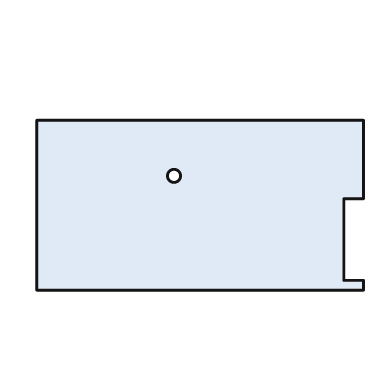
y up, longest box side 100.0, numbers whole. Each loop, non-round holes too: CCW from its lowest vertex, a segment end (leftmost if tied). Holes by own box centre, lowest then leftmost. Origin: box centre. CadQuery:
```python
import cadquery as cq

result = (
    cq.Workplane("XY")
    .moveTo(-50.0, -26.0)
    .lineTo(50.0, -26.0)
    .lineTo(50.0, -23.0)
    .lineTo(44.0, -23.0)
    .lineTo(44.0, 2.0)
    .lineTo(50.0, 2.0)
    .lineTo(50.0, 26.0)
    .lineTo(-50.0, 26.0)
    .close()
    .moveTo(-8.0, 9.0)
    .circle(2.0)
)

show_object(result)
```